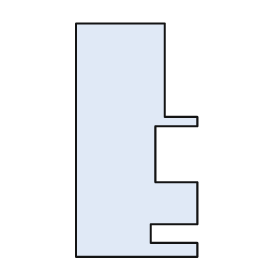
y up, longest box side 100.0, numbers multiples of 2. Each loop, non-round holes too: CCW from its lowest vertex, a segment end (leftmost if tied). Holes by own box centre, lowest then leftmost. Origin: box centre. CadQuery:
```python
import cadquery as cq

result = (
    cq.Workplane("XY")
    .moveTo(-26.0, -50.0)
    .lineTo(26.0, -50.0)
    .lineTo(26.0, -44.0)
    .lineTo(6.0, -44.0)
    .lineTo(6.0, -36.0)
    .lineTo(26.0, -36.0)
    .lineTo(26.0, -18.0)
    .lineTo(8.0, -18.0)
    .lineTo(8.0, 6.0)
    .lineTo(26.0, 6.0)
    .lineTo(26.0, 10.0)
    .lineTo(12.0, 10.0)
    .lineTo(12.0, 50.0)
    .lineTo(-26.0, 50.0)
    .close()
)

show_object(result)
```